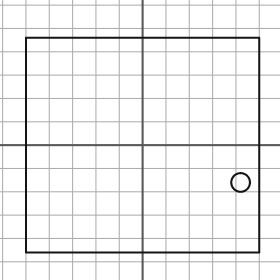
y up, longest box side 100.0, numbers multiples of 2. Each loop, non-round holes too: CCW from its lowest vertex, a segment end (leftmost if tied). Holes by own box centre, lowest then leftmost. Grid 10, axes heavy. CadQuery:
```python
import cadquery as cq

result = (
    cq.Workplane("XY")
    .moveTo(-50.0, -46.0)
    .lineTo(50.0, -46.0)
    .lineTo(50.0, 46.0)
    .lineTo(-50.0, 46.0)
    .close()
    .moveTo(42.0, -16.0)
    .circle(4.0)
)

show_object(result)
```